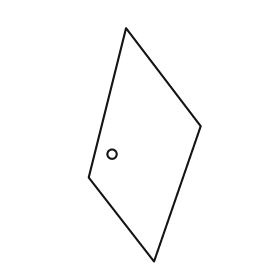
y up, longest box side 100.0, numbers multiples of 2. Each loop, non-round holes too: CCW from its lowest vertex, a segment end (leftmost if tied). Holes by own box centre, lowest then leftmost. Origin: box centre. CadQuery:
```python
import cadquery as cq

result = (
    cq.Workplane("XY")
    .moveTo(4.0, -50.0)
    .lineTo(24.0, 8.0)
    .lineTo(-8.0, 50.0)
    .lineTo(-24.0, -14.0)
    .close()
    .moveTo(-14.0, -4.0)
    .circle(2.0)
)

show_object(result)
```